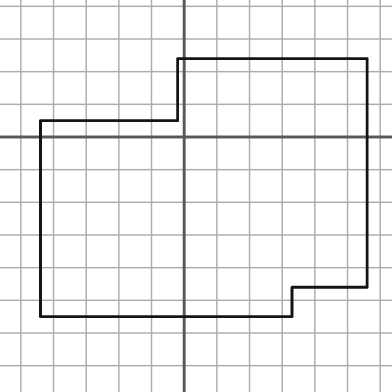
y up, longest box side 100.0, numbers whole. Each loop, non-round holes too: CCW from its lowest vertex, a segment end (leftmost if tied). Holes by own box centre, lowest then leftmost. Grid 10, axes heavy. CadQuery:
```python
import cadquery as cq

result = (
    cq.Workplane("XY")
    .moveTo(-44.0, -55.0)
    .lineTo(33.0, -55.0)
    .lineTo(33.0, -46.0)
    .lineTo(56.0, -46.0)
    .lineTo(56.0, 24.0)
    .lineTo(-2.0, 24.0)
    .lineTo(-2.0, 5.0)
    .lineTo(-44.0, 5.0)
    .close()
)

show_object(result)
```